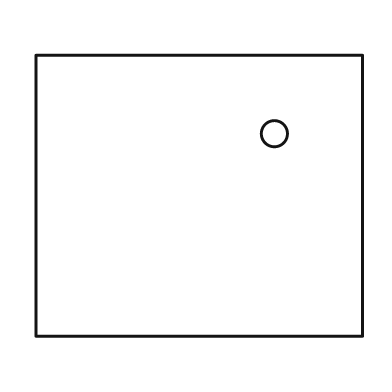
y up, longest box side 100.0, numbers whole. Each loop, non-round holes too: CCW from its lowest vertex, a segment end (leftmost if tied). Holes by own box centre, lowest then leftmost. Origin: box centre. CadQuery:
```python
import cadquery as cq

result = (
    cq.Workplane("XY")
    .moveTo(-50.0, -43.0)
    .lineTo(50.0, -43.0)
    .lineTo(50.0, 43.0)
    .lineTo(-50.0, 43.0)
    .close()
    .moveTo(23.0, 19.0)
    .circle(4.0)
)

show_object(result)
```